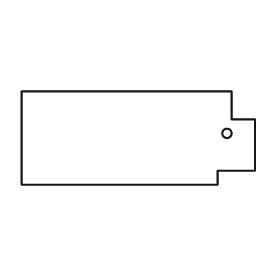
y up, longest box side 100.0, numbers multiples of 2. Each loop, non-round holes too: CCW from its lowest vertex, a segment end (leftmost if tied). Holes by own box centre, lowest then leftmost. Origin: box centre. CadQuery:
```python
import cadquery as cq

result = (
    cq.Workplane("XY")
    .moveTo(-50.0, -20.0)
    .lineTo(34.0, -20.0)
    .lineTo(34.0, -14.0)
    .lineTo(50.0, -14.0)
    .lineTo(50.0, 8.0)
    .lineTo(40.0, 8.0)
    .lineTo(40.0, 20.0)
    .lineTo(-50.0, 20.0)
    .close()
    .moveTo(38.0, 2.0)
    .circle(2.0)
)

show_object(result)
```